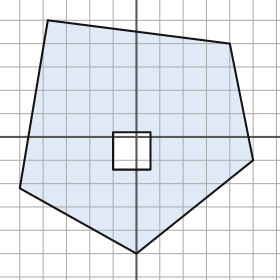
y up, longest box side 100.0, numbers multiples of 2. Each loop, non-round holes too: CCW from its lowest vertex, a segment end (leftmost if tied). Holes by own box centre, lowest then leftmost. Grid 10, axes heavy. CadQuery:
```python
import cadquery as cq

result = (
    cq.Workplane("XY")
    .moveTo(0.0, -50.0)
    .lineTo(50.0, -10.0)
    .lineTo(40.0, 40.0)
    .lineTo(-38.0, 50.0)
    .lineTo(-50.0, -22.0)
    .close()
    .moveTo(-10.0, -14.0)
    .lineTo(6.0, -14.0)
    .lineTo(6.0, 2.0)
    .lineTo(-10.0, 2.0)
    .close()
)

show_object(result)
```